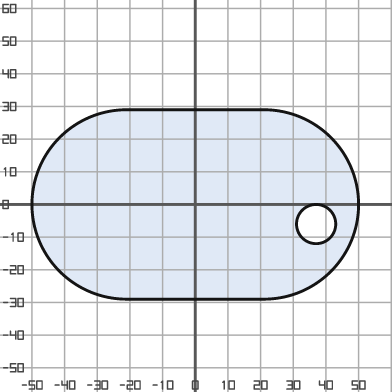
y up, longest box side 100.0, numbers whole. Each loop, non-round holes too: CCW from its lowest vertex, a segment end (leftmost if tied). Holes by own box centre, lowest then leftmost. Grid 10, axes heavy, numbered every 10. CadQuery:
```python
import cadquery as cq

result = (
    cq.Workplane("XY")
    .moveTo(-21.0, -29.0)
    .lineTo(21.0, -29.0)
    .threePointArc((50.0, 0.0), (21.0, 29.0))
    .lineTo(-21.0, 29.0)
    .threePointArc((-50.0, 0.0), (-21.0, -29.0))
    .close()
    .moveTo(37.0, -6.0)
    .circle(6.0)
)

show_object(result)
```